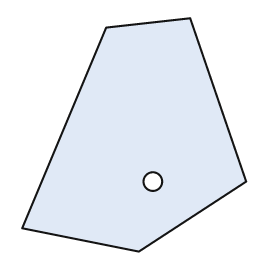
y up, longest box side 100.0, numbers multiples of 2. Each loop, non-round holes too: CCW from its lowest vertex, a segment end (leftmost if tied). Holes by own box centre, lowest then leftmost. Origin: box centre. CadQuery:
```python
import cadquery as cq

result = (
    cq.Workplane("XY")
    .moveTo(2.0, -50.0)
    .lineTo(48.0, -20.0)
    .lineTo(24.0, 50.0)
    .lineTo(-12.0, 46.0)
    .lineTo(-48.0, -40.0)
    .close()
    .moveTo(8.0, -20.0)
    .circle(4.0)
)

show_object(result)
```